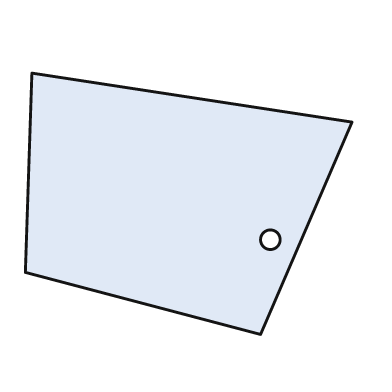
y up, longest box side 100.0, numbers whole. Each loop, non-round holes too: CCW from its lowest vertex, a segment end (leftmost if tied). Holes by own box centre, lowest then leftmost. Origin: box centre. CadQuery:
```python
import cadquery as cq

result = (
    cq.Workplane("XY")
    .moveTo(22.0, -40.0)
    .lineTo(50.0, 25.0)
    .lineTo(-48.0, 40.0)
    .lineTo(-50.0, -21.0)
    .close()
    .moveTo(25.0, -11.0)
    .circle(3.0)
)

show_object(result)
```